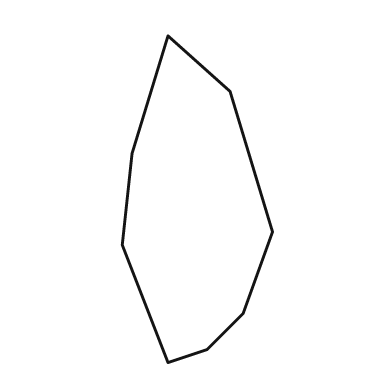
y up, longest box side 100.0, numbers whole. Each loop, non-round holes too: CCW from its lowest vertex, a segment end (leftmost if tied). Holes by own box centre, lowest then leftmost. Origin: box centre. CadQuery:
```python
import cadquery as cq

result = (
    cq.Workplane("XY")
    .moveTo(-9.0, -50.0)
    .lineTo(3.0, -46.0)
    .lineTo(14.0, -35.0)
    .lineTo(23.0, -10.0)
    .lineTo(10.0, 33.0)
    .lineTo(-9.0, 50.0)
    .lineTo(-20.0, 14.0)
    .lineTo(-23.0, -14.0)
    .close()
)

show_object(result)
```